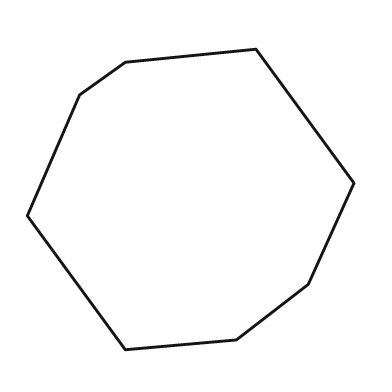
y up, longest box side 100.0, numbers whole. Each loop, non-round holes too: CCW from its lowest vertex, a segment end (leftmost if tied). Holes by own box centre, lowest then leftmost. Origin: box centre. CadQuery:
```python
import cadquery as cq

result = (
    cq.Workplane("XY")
    .moveTo(-20.0, -46.0)
    .lineTo(14.0, -43.0)
    .lineTo(36.0, -26.0)
    .lineTo(50.0, 5.0)
    .lineTo(20.0, 46.0)
    .lineTo(-20.0, 42.0)
    .lineTo(-34.0, 32.0)
    .lineTo(-50.0, -5.0)
    .close()
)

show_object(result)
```